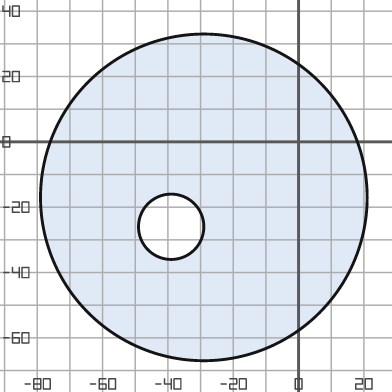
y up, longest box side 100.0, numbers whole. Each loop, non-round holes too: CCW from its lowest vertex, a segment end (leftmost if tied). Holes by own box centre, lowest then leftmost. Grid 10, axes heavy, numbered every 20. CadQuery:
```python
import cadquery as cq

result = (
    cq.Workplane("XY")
    .moveTo(-29.0, -17.0)
    .circle(50.0)
    .moveTo(-39.0, -26.0)
    .circle(10.0)
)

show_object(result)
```